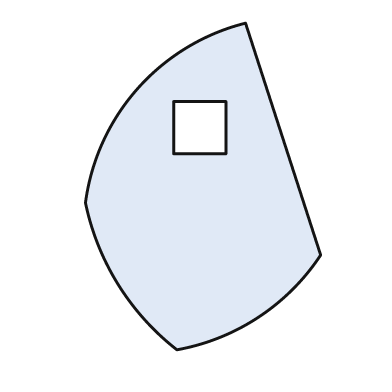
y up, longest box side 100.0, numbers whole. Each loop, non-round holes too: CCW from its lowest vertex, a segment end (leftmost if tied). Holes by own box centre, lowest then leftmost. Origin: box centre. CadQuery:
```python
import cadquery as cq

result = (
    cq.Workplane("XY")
    .moveTo(-8.0, -50.0)
    .threePointArc((17.0, -40.0), (36.0, -21.0))
    .lineTo(13.0, 50.0)
    .threePointArc((-20.0, 30.0), (-36.0, -5.0))
    .threePointArc((-26.0, -30.0), (-8.0, -50.0))
    .close()
    .moveTo(-9.0, 10.0)
    .lineTo(7.0, 10.0)
    .lineTo(7.0, 26.0)
    .lineTo(-9.0, 26.0)
    .close()
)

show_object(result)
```